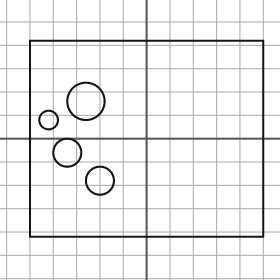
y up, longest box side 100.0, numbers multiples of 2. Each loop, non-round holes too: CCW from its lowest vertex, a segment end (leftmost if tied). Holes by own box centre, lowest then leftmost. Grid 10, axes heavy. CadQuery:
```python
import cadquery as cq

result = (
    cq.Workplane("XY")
    .moveTo(-50.0, -42.0)
    .lineTo(50.0, -42.0)
    .lineTo(50.0, 42.0)
    .lineTo(-50.0, 42.0)
    .close()
    .moveTo(-20.0, -18.0)
    .circle(6.0)
    .moveTo(-34.0, -6.0)
    .circle(6.0)
    .moveTo(-42.0, 8.0)
    .circle(4.0)
    .moveTo(-26.0, 16.0)
    .circle(8.0)
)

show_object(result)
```